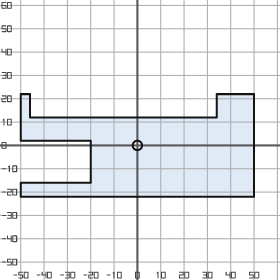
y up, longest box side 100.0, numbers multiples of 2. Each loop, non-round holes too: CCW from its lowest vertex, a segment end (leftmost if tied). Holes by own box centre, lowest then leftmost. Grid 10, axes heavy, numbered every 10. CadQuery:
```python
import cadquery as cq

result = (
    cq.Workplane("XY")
    .moveTo(-50.0, -22.0)
    .lineTo(50.0, -22.0)
    .lineTo(50.0, 22.0)
    .lineTo(34.0, 22.0)
    .lineTo(34.0, 12.0)
    .lineTo(-46.0, 12.0)
    .lineTo(-46.0, 22.0)
    .lineTo(-50.0, 22.0)
    .lineTo(-50.0, 2.0)
    .lineTo(-20.0, 2.0)
    .lineTo(-20.0, -16.0)
    .lineTo(-50.0, -16.0)
    .close()
    .moveTo(0.0, 0.0)
    .circle(2.0)
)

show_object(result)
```